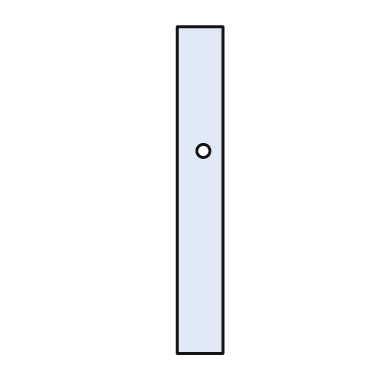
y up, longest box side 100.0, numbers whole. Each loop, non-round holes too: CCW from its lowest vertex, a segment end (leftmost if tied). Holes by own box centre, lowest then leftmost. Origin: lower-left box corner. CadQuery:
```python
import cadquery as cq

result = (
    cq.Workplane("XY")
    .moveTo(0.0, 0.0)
    .lineTo(14.0, 0.0)
    .lineTo(14.0, 100.0)
    .lineTo(0.0, 100.0)
    .close()
    .moveTo(8.0, 62.0)
    .circle(2.0)
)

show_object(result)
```